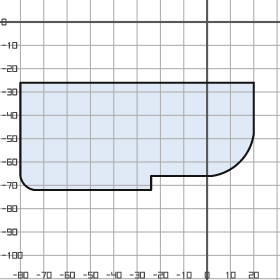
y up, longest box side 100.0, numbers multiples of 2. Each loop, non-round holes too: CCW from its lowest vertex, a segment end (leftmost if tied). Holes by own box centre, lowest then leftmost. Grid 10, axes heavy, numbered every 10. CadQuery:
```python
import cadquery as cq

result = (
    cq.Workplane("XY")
    .moveTo(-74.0, -72.0)
    .lineTo(-24.0, -72.0)
    .lineTo(-24.0, -66.0)
    .lineTo(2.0, -66.0)
    .threePointArc((14.0, -60.0), (20.0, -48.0))
    .lineTo(20.0, -26.0)
    .lineTo(-80.0, -26.0)
    .lineTo(-80.0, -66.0)
    .threePointArc((-78.0, -70.0), (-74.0, -72.0))
    .close()
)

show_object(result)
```